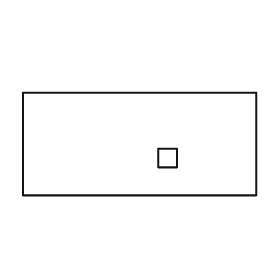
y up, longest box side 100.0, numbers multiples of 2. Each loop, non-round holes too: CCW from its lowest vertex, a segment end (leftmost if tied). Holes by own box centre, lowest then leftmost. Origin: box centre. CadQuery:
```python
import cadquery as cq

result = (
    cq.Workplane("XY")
    .moveTo(-50.0, -22.0)
    .lineTo(50.0, -22.0)
    .lineTo(50.0, 22.0)
    .lineTo(-50.0, 22.0)
    .close()
    .moveTo(8.0, -10.0)
    .lineTo(16.0, -10.0)
    .lineTo(16.0, -2.0)
    .lineTo(8.0, -2.0)
    .close()
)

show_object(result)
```